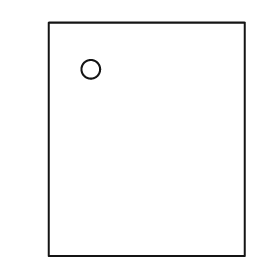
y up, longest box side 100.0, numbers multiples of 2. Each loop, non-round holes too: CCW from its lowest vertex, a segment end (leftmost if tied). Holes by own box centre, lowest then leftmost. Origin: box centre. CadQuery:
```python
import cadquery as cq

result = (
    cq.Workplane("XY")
    .moveTo(-42.0, -50.0)
    .lineTo(42.0, -50.0)
    .lineTo(42.0, 50.0)
    .lineTo(-42.0, 50.0)
    .close()
    .moveTo(-24.0, 30.0)
    .circle(4.0)
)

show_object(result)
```